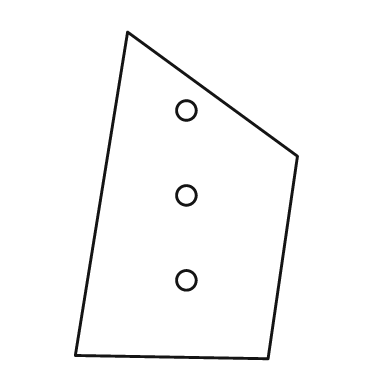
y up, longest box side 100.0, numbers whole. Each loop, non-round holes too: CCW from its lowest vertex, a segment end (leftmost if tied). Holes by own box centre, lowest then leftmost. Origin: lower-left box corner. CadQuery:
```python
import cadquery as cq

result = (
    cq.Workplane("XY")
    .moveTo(59.0, 0.0)
    .lineTo(68.0, 62.0)
    .lineTo(16.0, 100.0)
    .lineTo(0.0, 1.0)
    .close()
    .moveTo(34.0, 24.0)
    .circle(3.0)
    .moveTo(34.0, 50.0)
    .circle(3.0)
    .moveTo(34.0, 76.0)
    .circle(3.0)
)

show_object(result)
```